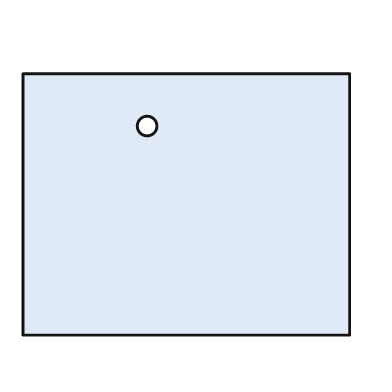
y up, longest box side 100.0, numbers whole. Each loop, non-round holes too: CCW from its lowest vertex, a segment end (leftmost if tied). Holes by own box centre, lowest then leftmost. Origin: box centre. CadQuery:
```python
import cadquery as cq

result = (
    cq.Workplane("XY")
    .moveTo(-50.0, -40.0)
    .lineTo(50.0, -40.0)
    .lineTo(50.0, 40.0)
    .lineTo(-50.0, 40.0)
    .close()
    .moveTo(-12.0, 24.0)
    .circle(3.0)
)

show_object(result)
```